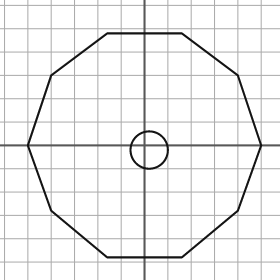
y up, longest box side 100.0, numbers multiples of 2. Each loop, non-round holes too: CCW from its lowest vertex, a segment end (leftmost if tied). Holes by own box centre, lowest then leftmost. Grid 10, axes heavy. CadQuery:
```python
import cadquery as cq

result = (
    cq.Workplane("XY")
    .moveTo(-16.0, -48.0)
    .lineTo(16.0, -48.0)
    .lineTo(40.0, -28.0)
    .lineTo(50.0, 0.0)
    .lineTo(40.0, 30.0)
    .lineTo(16.0, 48.0)
    .lineTo(-16.0, 48.0)
    .lineTo(-40.0, 30.0)
    .lineTo(-50.0, 0.0)
    .lineTo(-40.0, -28.0)
    .close()
    .moveTo(2.0, -2.0)
    .circle(8.0)
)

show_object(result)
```